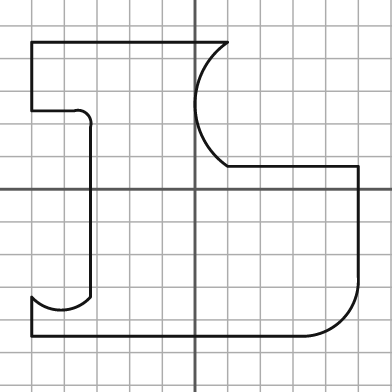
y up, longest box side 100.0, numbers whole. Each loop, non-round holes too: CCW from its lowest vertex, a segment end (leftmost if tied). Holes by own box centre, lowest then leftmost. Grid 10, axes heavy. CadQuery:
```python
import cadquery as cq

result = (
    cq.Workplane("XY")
    .moveTo(-50.0, -45.0)
    .lineTo(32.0, -45.0)
    .threePointArc((45.0, -40.0), (50.0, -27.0))
    .lineTo(50.0, 7.0)
    .lineTo(10.0, 7.0)
    .threePointArc((0.0, 26.0), (10.0, 45.0))
    .lineTo(-50.0, 45.0)
    .lineTo(-50.0, 24.0)
    .lineTo(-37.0, 24.0)
    .threePointArc((-33.0, 23.0), (-32.0, 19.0))
    .lineTo(-32.0, -33.0)
    .threePointArc((-41.0, -37.0), (-50.0, -33.0))
    .close()
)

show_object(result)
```